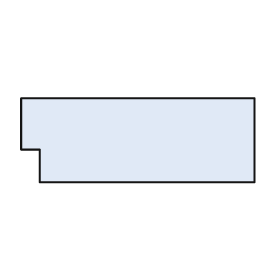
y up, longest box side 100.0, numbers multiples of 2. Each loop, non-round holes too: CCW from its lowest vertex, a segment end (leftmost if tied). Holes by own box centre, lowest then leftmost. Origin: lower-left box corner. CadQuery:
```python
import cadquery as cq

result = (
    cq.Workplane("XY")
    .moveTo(8.0, 0.0)
    .lineTo(100.0, 0.0)
    .lineTo(100.0, 36.0)
    .lineTo(0.0, 36.0)
    .lineTo(0.0, 14.0)
    .lineTo(8.0, 14.0)
    .close()
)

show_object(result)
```